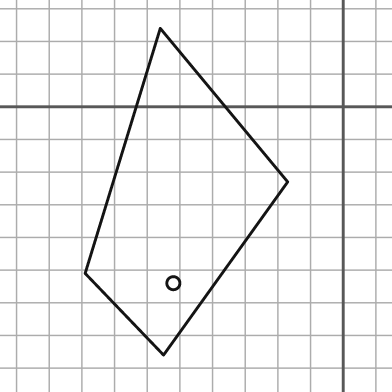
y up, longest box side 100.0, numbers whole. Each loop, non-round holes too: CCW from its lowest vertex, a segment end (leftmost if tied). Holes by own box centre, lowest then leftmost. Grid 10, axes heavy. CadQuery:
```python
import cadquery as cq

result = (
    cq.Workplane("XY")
    .moveTo(-55.0, -76.0)
    .lineTo(-17.0, -23.0)
    .lineTo(-56.0, 24.0)
    .lineTo(-79.0, -51.0)
    .close()
    .moveTo(-52.0, -54.0)
    .circle(2.0)
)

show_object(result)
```